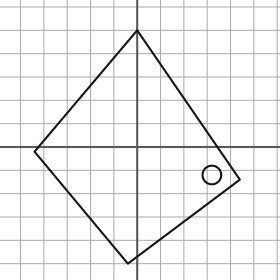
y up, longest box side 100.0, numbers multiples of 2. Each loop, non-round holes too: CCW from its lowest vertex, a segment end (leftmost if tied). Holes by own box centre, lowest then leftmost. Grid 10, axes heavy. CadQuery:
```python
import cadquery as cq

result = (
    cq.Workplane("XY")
    .moveTo(-4.0, -50.0)
    .lineTo(44.0, -14.0)
    .lineTo(0.0, 50.0)
    .lineTo(-44.0, -2.0)
    .close()
    .moveTo(32.0, -12.0)
    .circle(4.0)
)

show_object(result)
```